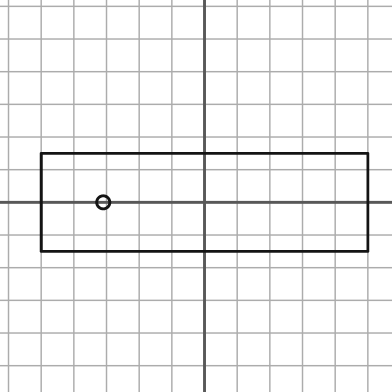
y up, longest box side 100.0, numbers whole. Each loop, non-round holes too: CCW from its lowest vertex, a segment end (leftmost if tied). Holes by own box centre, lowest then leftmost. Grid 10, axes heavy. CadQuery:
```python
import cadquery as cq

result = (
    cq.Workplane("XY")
    .moveTo(-50.0, -15.0)
    .lineTo(50.0, -15.0)
    .lineTo(50.0, 15.0)
    .lineTo(-50.0, 15.0)
    .close()
    .moveTo(-31.0, 0.0)
    .circle(2.0)
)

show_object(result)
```